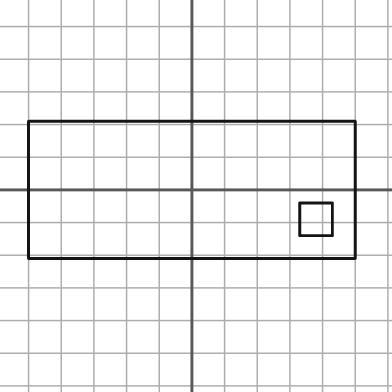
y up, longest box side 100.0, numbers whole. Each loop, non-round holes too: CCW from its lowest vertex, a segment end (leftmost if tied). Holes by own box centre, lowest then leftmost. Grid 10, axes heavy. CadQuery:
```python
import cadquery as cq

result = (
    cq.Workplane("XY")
    .moveTo(-50.0, -21.0)
    .lineTo(50.0, -21.0)
    .lineTo(50.0, 21.0)
    .lineTo(-50.0, 21.0)
    .close()
    .moveTo(33.0, -14.0)
    .lineTo(43.0, -14.0)
    .lineTo(43.0, -4.0)
    .lineTo(33.0, -4.0)
    .close()
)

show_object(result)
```